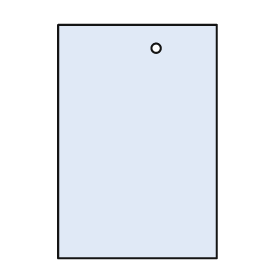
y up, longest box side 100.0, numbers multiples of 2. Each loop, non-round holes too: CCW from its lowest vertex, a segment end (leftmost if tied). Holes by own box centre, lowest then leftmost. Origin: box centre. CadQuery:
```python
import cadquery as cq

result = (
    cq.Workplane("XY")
    .moveTo(-34.0, -50.0)
    .lineTo(34.0, -50.0)
    .lineTo(34.0, 50.0)
    .lineTo(-34.0, 50.0)
    .close()
    .moveTo(8.0, 40.0)
    .circle(2.0)
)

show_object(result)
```